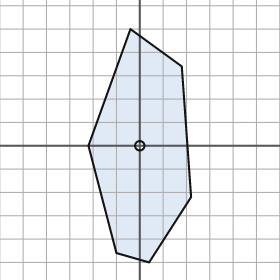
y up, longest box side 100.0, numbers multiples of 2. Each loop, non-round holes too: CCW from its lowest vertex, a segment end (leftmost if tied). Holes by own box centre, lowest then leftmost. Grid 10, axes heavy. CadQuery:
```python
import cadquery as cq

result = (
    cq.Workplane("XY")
    .moveTo(4.0, -50.0)
    .lineTo(22.0, -22.0)
    .lineTo(18.0, 34.0)
    .lineTo(-4.0, 50.0)
    .lineTo(-22.0, 0.0)
    .lineTo(-10.0, -46.0)
    .close()
    .moveTo(0.0, 0.0)
    .circle(2.0)
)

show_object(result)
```